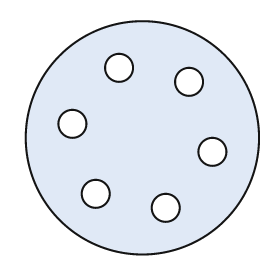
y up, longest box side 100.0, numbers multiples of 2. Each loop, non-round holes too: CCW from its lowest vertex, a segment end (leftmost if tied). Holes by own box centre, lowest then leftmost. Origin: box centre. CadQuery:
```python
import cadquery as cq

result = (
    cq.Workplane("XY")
    .moveTo(0.0, 0.0)
    .circle(50.0)
    .moveTo(10.0, -30.0)
    .circle(6.0)
    .moveTo(-20.0, -24.0)
    .circle(6.0)
    .moveTo(30.0, -6.0)
    .circle(6.0)
    .moveTo(-30.0, 6.0)
    .circle(6.0)
    .moveTo(20.0, 24.0)
    .circle(6.0)
    .moveTo(-10.0, 30.0)
    .circle(6.0)
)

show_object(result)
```